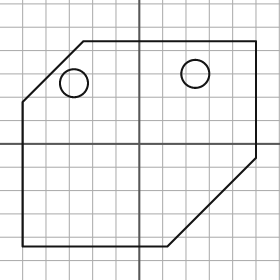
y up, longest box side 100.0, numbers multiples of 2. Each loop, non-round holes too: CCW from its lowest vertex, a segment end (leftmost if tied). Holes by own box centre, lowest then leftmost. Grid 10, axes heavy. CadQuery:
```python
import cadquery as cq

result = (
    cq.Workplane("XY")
    .moveTo(-50.0, -44.0)
    .lineTo(12.0, -44.0)
    .lineTo(50.0, -6.0)
    .lineTo(50.0, 44.0)
    .lineTo(-24.0, 44.0)
    .lineTo(-50.0, 18.0)
    .close()
    .moveTo(-28.0, 26.0)
    .circle(6.0)
    .moveTo(24.0, 30.0)
    .circle(6.0)
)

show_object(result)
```